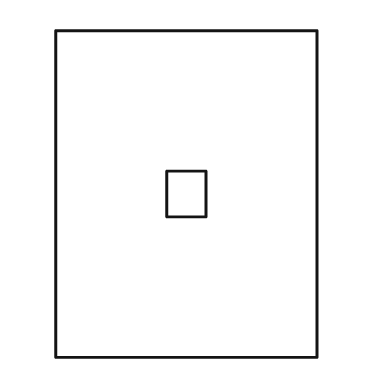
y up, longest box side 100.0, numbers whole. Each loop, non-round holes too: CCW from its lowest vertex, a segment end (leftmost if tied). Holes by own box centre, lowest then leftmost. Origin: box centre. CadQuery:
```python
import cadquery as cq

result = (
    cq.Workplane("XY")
    .moveTo(-40.0, -50.0)
    .lineTo(40.0, -50.0)
    .lineTo(40.0, 50.0)
    .lineTo(-40.0, 50.0)
    .close()
    .moveTo(-6.0, -7.0)
    .lineTo(6.0, -7.0)
    .lineTo(6.0, 7.0)
    .lineTo(-6.0, 7.0)
    .close()
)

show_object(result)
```